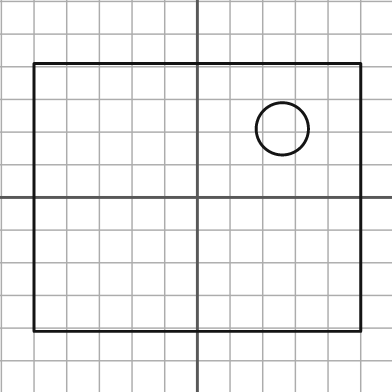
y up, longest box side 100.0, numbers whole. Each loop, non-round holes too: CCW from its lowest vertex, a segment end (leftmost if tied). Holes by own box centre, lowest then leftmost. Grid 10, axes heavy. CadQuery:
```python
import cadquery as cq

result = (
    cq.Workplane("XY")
    .moveTo(-50.0, -41.0)
    .lineTo(50.0, -41.0)
    .lineTo(50.0, 41.0)
    .lineTo(-50.0, 41.0)
    .close()
    .moveTo(26.0, 21.0)
    .circle(8.0)
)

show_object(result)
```